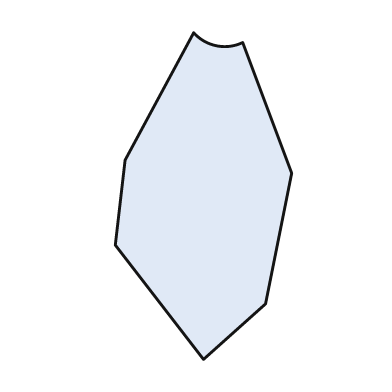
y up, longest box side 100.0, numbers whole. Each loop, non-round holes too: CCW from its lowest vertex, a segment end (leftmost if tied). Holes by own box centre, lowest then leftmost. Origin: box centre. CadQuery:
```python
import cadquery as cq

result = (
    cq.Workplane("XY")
    .moveTo(0.0, -50.0)
    .lineTo(19.0, -33.0)
    .lineTo(27.0, 7.0)
    .lineTo(12.0, 47.0)
    .threePointArc((4.0, 46.0), (-3.0, 50.0))
    .lineTo(-24.0, 11.0)
    .lineTo(-27.0, -15.0)
    .close()
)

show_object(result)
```